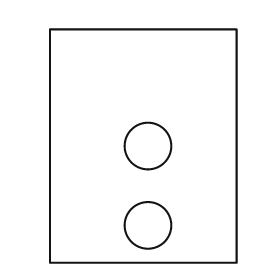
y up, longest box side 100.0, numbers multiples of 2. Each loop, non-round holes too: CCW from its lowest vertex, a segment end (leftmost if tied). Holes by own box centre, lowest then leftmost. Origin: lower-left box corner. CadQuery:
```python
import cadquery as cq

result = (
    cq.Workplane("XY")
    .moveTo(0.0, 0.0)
    .lineTo(80.0, 0.0)
    .lineTo(80.0, 100.0)
    .lineTo(0.0, 100.0)
    .close()
    .moveTo(42.0, 16.0)
    .circle(10.0)
    .moveTo(42.0, 50.0)
    .circle(10.0)
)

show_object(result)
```